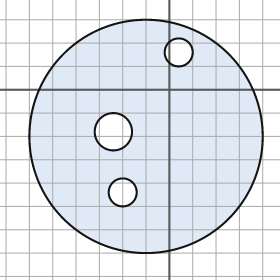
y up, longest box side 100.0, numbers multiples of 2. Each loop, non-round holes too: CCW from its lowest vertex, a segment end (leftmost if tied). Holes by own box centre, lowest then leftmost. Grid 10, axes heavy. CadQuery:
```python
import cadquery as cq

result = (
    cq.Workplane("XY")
    .moveTo(-10.0, -20.0)
    .circle(50.0)
    .moveTo(-20.0, -44.0)
    .circle(6.0)
    .moveTo(-24.0, -18.0)
    .circle(8.0)
    .moveTo(4.0, 16.0)
    .circle(6.0)
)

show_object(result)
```